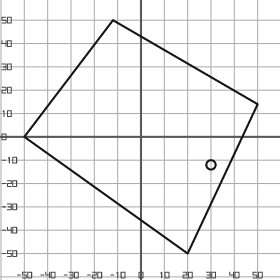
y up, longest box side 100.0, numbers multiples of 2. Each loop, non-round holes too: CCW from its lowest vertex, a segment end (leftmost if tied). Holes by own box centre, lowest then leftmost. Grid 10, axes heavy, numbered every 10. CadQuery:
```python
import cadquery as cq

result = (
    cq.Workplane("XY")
    .moveTo(20.0, -50.0)
    .lineTo(50.0, 14.0)
    .lineTo(-12.0, 50.0)
    .lineTo(-50.0, 0.0)
    .close()
    .moveTo(30.0, -12.0)
    .circle(2.0)
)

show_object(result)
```